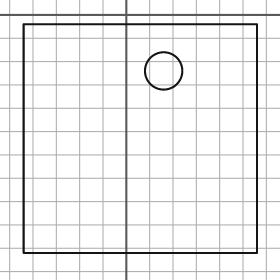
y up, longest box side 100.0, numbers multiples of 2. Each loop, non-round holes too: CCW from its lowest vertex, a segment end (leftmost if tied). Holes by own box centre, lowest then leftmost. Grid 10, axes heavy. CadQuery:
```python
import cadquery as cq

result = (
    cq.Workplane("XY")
    .moveTo(-44.0, -102.0)
    .lineTo(56.0, -102.0)
    .lineTo(56.0, -4.0)
    .lineTo(-44.0, -4.0)
    .close()
    .moveTo(16.0, -24.0)
    .circle(8.0)
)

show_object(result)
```